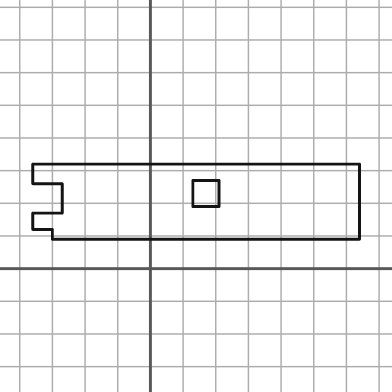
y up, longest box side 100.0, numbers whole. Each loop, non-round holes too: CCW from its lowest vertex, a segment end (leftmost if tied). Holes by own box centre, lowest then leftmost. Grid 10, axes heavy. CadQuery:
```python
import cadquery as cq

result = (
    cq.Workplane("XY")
    .moveTo(-30.0, 9.0)
    .lineTo(64.0, 9.0)
    .lineTo(64.0, 32.0)
    .lineTo(-36.0, 32.0)
    .lineTo(-36.0, 26.0)
    .lineTo(-27.0, 26.0)
    .lineTo(-27.0, 17.0)
    .lineTo(-36.0, 17.0)
    .lineTo(-36.0, 12.0)
    .lineTo(-30.0, 12.0)
    .close()
    .moveTo(13.0, 19.0)
    .lineTo(21.0, 19.0)
    .lineTo(21.0, 27.0)
    .lineTo(13.0, 27.0)
    .close()
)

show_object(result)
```